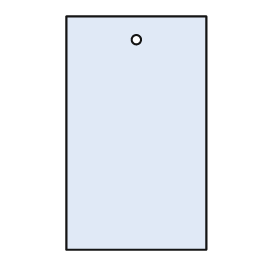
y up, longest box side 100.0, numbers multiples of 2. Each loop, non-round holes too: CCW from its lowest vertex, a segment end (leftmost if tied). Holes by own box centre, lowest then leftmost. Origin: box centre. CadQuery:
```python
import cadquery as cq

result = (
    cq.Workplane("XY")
    .moveTo(-30.0, -50.0)
    .lineTo(30.0, -50.0)
    .lineTo(30.0, 50.0)
    .lineTo(-30.0, 50.0)
    .close()
    .moveTo(0.0, 40.0)
    .circle(2.0)
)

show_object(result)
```